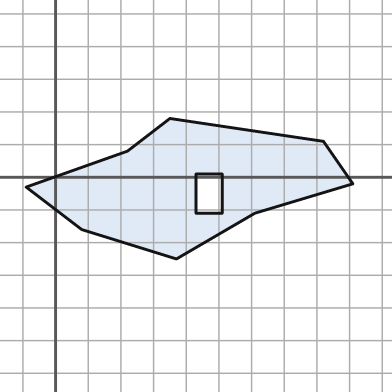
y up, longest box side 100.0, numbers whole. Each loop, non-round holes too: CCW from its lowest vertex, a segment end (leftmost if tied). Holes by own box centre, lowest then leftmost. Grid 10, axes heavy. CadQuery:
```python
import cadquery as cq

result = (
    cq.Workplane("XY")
    .moveTo(37.0, -25.0)
    .lineTo(61.0, -11.0)
    .lineTo(91.0, -2.0)
    .lineTo(82.0, 11.0)
    .lineTo(35.0, 18.0)
    .lineTo(22.0, 8.0)
    .lineTo(-9.0, -3.0)
    .lineTo(8.0, -16.0)
    .close()
    .moveTo(43.0, -11.0)
    .lineTo(51.0, -11.0)
    .lineTo(51.0, 1.0)
    .lineTo(43.0, 1.0)
    .close()
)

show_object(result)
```